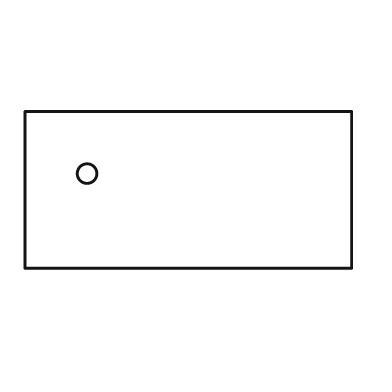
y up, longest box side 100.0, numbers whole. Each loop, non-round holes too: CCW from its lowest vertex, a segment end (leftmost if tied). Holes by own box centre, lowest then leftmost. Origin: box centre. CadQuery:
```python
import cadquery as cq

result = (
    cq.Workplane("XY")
    .moveTo(-50.0, -24.0)
    .lineTo(50.0, -24.0)
    .lineTo(50.0, 24.0)
    .lineTo(-50.0, 24.0)
    .close()
    .moveTo(-31.0, 5.0)
    .circle(3.0)
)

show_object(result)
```